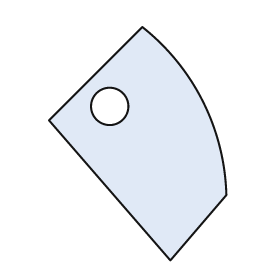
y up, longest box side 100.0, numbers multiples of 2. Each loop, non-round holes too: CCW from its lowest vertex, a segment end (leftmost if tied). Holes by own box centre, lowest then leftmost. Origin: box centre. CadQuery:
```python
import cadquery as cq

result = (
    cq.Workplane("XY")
    .moveTo(14.0, -50.0)
    .lineTo(38.0, -22.0)
    .threePointArc((28.0, 18.0), (2.0, 50.0))
    .lineTo(-38.0, 10.0)
    .close()
    .moveTo(-12.0, 16.0)
    .circle(8.0)
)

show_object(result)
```